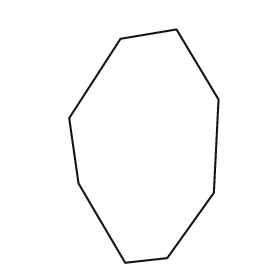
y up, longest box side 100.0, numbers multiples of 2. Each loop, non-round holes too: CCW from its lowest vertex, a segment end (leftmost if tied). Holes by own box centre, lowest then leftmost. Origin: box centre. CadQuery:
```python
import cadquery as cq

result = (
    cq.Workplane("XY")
    .moveTo(-8.0, -50.0)
    .lineTo(10.0, -48.0)
    .lineTo(30.0, -20.0)
    .lineTo(32.0, 20.0)
    .lineTo(14.0, 50.0)
    .lineTo(-10.0, 46.0)
    .lineTo(-32.0, 12.0)
    .lineTo(-28.0, -16.0)
    .close()
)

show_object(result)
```